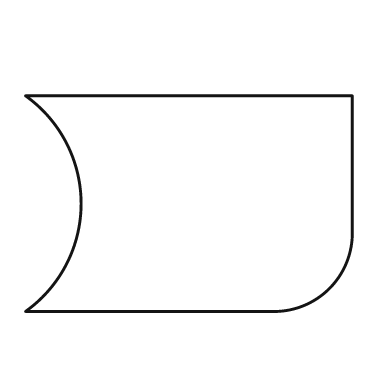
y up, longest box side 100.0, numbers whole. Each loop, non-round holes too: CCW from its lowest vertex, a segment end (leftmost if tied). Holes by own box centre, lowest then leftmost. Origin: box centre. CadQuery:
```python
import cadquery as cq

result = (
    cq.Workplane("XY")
    .moveTo(-50.0, -33.0)
    .lineTo(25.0, -33.0)
    .threePointArc((43.0, -26.0), (50.0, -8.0))
    .lineTo(50.0, 33.0)
    .lineTo(-50.0, 33.0)
    .threePointArc((-33.0, 0.0), (-50.0, -33.0))
    .close()
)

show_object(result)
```